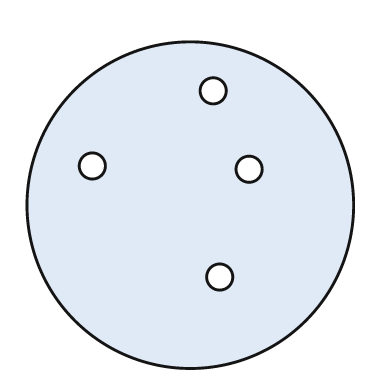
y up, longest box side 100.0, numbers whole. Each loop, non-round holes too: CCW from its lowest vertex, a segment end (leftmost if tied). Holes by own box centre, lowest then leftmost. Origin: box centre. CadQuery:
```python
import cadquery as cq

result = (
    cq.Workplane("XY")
    .moveTo(0.0, 0.0)
    .circle(50.0)
    .moveTo(9.0, -22.0)
    .circle(4.0)
    .moveTo(18.0, 11.0)
    .circle(4.0)
    .moveTo(-30.0, 12.0)
    .circle(4.0)
    .moveTo(7.0, 35.0)
    .circle(4.0)
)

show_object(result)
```